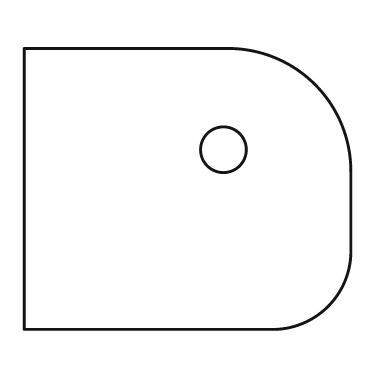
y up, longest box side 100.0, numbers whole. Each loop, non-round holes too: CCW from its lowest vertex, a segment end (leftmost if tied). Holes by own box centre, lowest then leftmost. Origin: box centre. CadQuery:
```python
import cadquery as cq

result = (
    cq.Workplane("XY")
    .moveTo(-50.0, -43.0)
    .lineTo(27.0, -43.0)
    .threePointArc((43.0, -36.0), (50.0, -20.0))
    .lineTo(50.0, 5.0)
    .threePointArc((39.0, 32.0), (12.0, 43.0))
    .lineTo(-50.0, 43.0)
    .close()
    .moveTo(11.0, 12.0)
    .circle(7.0)
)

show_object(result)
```